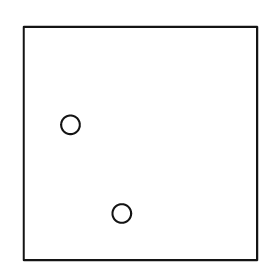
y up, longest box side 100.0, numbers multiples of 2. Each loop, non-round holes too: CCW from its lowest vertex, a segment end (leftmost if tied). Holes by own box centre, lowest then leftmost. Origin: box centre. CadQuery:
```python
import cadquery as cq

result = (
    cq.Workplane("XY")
    .moveTo(-50.0, -50.0)
    .lineTo(50.0, -50.0)
    .lineTo(50.0, 50.0)
    .lineTo(-50.0, 50.0)
    .close()
    .moveTo(-8.0, -30.0)
    .circle(4.0)
    .moveTo(-30.0, 8.0)
    .circle(4.0)
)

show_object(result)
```